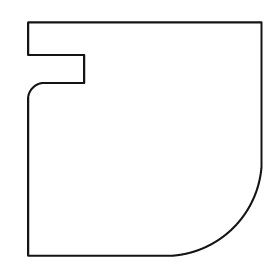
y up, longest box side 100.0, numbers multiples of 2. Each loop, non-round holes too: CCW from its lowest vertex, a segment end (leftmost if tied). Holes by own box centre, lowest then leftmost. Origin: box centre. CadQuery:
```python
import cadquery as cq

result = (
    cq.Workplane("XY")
    .moveTo(-50.0, -50.0)
    .lineTo(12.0, -50.0)
    .threePointArc((38.0, -38.0), (50.0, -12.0))
    .lineTo(50.0, 50.0)
    .lineTo(-50.0, 50.0)
    .lineTo(-50.0, 36.0)
    .lineTo(-26.0, 36.0)
    .lineTo(-26.0, 24.0)
    .lineTo(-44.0, 24.0)
    .threePointArc((-48.0, 22.0), (-50.0, 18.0))
    .close()
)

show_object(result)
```